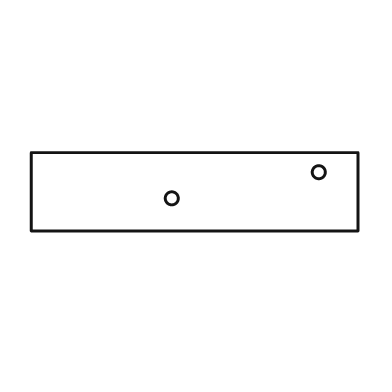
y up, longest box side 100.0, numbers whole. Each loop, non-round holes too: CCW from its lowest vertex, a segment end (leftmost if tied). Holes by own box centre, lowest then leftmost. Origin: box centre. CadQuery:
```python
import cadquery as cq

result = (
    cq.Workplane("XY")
    .moveTo(-50.0, -12.0)
    .lineTo(50.0, -12.0)
    .lineTo(50.0, 12.0)
    .lineTo(-50.0, 12.0)
    .close()
    .moveTo(-7.0, -2.0)
    .circle(2.0)
    .moveTo(38.0, 6.0)
    .circle(2.0)
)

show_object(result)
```